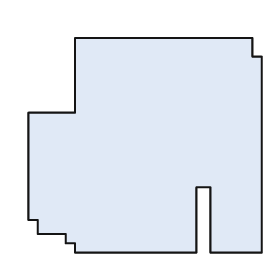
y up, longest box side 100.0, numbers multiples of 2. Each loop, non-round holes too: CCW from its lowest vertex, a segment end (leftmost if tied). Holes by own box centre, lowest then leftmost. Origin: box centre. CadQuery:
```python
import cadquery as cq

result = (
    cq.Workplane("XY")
    .moveTo(-30.0, -46.0)
    .lineTo(22.0, -46.0)
    .lineTo(22.0, -18.0)
    .lineTo(28.0, -18.0)
    .lineTo(28.0, -46.0)
    .lineTo(50.0, -46.0)
    .lineTo(50.0, 38.0)
    .lineTo(46.0, 38.0)
    .lineTo(46.0, 46.0)
    .lineTo(-30.0, 46.0)
    .lineTo(-30.0, 14.0)
    .lineTo(-50.0, 14.0)
    .lineTo(-50.0, -32.0)
    .lineTo(-46.0, -32.0)
    .lineTo(-46.0, -38.0)
    .lineTo(-34.0, -38.0)
    .lineTo(-34.0, -42.0)
    .lineTo(-30.0, -42.0)
    .close()
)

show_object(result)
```